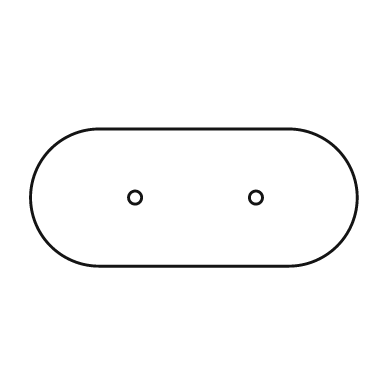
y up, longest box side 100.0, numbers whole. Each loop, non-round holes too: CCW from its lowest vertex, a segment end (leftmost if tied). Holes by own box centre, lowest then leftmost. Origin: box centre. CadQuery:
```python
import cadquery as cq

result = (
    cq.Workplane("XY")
    .moveTo(-29.0, -21.0)
    .lineTo(29.0, -21.0)
    .threePointArc((50.0, 0.0), (29.0, 21.0))
    .lineTo(-29.0, 21.0)
    .threePointArc((-50.0, 0.0), (-29.0, -21.0))
    .close()
    .moveTo(-18.0, 0.0)
    .circle(2.0)
    .moveTo(19.0, 0.0)
    .circle(2.0)
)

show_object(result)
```